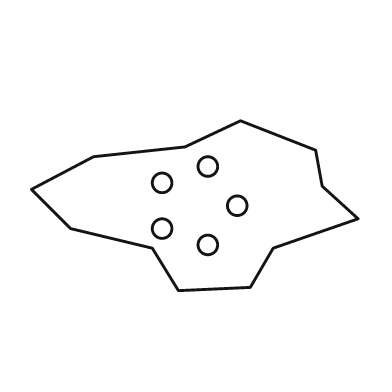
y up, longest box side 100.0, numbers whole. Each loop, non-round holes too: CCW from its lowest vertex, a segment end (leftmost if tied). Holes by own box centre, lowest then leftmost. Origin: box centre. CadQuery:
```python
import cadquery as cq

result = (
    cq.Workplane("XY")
    .moveTo(-5.0, -26.0)
    .lineTo(17.0, -25.0)
    .lineTo(24.0, -13.0)
    .lineTo(50.0, -4.0)
    .lineTo(39.0, 6.0)
    .lineTo(37.0, 17.0)
    .lineTo(14.0, 26.0)
    .lineTo(-3.0, 18.0)
    .lineTo(-31.0, 15.0)
    .lineTo(-50.0, 5.0)
    .lineTo(-38.0, -7.0)
    .lineTo(-13.0, -13.0)
    .close()
    .moveTo(4.0, -12.0)
    .circle(3.0)
    .moveTo(-10.0, -7.0)
    .circle(3.0)
    .moveTo(13.0, 0.0)
    .circle(3.0)
    .moveTo(-10.0, 7.0)
    .circle(3.0)
    .moveTo(4.0, 12.0)
    .circle(3.0)
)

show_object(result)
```